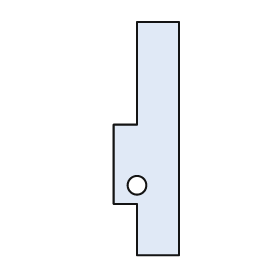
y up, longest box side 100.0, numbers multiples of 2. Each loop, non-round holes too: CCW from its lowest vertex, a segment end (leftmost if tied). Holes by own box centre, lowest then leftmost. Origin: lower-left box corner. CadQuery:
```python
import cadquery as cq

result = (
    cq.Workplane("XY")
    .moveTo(10.0, 0.0)
    .lineTo(28.0, 0.0)
    .lineTo(28.0, 100.0)
    .lineTo(10.0, 100.0)
    .lineTo(10.0, 56.0)
    .lineTo(0.0, 56.0)
    .lineTo(0.0, 22.0)
    .lineTo(10.0, 22.0)
    .close()
    .moveTo(10.0, 30.0)
    .circle(4.0)
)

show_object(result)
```